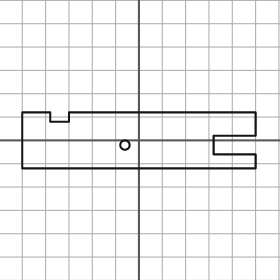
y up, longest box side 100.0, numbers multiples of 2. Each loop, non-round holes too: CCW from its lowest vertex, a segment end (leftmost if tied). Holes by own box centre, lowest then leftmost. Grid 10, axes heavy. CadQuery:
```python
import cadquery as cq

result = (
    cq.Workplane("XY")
    .moveTo(-50.0, -12.0)
    .lineTo(50.0, -12.0)
    .lineTo(50.0, -6.0)
    .lineTo(32.0, -6.0)
    .lineTo(32.0, 2.0)
    .lineTo(50.0, 2.0)
    .lineTo(50.0, 12.0)
    .lineTo(-30.0, 12.0)
    .lineTo(-30.0, 8.0)
    .lineTo(-38.0, 8.0)
    .lineTo(-38.0, 12.0)
    .lineTo(-50.0, 12.0)
    .close()
    .moveTo(-6.0, -2.0)
    .circle(2.0)
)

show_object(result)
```